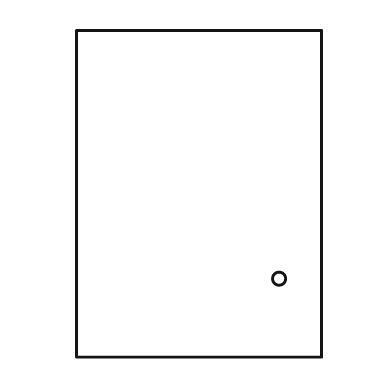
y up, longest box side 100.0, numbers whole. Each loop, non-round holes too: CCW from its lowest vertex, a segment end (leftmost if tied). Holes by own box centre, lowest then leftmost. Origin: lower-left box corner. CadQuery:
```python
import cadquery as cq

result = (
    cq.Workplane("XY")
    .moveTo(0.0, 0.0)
    .lineTo(75.0, 0.0)
    .lineTo(75.0, 100.0)
    .lineTo(0.0, 100.0)
    .close()
    .moveTo(62.0, 24.0)
    .circle(2.0)
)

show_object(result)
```